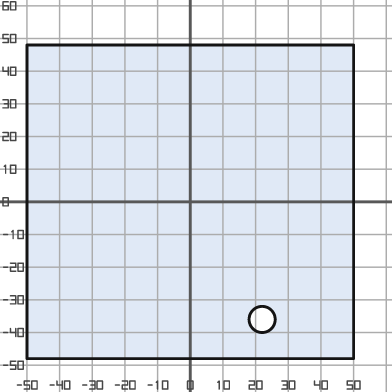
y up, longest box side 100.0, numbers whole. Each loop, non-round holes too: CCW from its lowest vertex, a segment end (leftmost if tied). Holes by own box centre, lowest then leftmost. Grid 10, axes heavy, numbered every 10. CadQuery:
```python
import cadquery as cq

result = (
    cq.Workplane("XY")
    .moveTo(-50.0, -48.0)
    .lineTo(50.0, -48.0)
    .lineTo(50.0, 48.0)
    .lineTo(-50.0, 48.0)
    .close()
    .moveTo(22.0, -36.0)
    .circle(4.0)
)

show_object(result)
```